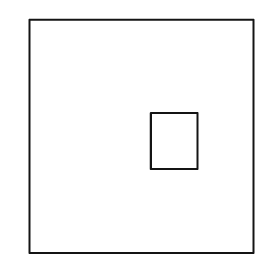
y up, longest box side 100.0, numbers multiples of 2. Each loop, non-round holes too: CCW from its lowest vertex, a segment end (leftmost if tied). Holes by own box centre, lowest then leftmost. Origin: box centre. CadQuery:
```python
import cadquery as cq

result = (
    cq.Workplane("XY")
    .moveTo(-48.0, -50.0)
    .lineTo(48.0, -50.0)
    .lineTo(48.0, 50.0)
    .lineTo(-48.0, 50.0)
    .close()
    .moveTo(4.0, -14.0)
    .lineTo(24.0, -14.0)
    .lineTo(24.0, 10.0)
    .lineTo(4.0, 10.0)
    .close()
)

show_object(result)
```